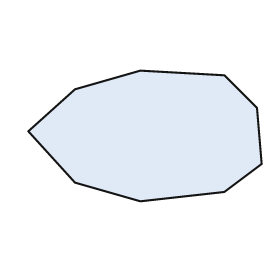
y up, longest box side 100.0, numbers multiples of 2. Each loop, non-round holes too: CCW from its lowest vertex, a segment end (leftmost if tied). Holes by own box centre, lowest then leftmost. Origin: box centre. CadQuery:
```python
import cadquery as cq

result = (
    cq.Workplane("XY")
    .moveTo(-2.0, -28.0)
    .lineTo(34.0, -24.0)
    .lineTo(50.0, -12.0)
    .lineTo(48.0, 12.0)
    .lineTo(34.0, 26.0)
    .lineTo(-2.0, 28.0)
    .lineTo(-30.0, 20.0)
    .lineTo(-50.0, 2.0)
    .lineTo(-30.0, -20.0)
    .close()
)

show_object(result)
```